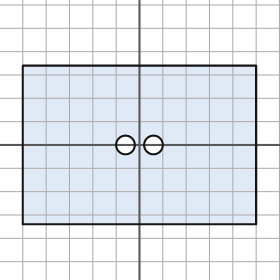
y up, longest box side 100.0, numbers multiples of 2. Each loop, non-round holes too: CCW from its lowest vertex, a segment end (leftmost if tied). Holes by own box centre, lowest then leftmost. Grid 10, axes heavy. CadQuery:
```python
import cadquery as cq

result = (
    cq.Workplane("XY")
    .moveTo(-50.0, -34.0)
    .lineTo(50.0, -34.0)
    .lineTo(50.0, 34.0)
    .lineTo(-50.0, 34.0)
    .close()
    .moveTo(-6.0, 0.0)
    .circle(4.0)
    .moveTo(6.0, 0.0)
    .circle(4.0)
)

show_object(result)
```